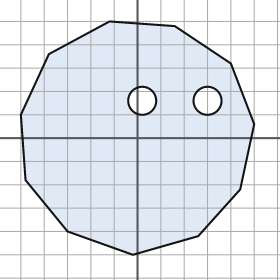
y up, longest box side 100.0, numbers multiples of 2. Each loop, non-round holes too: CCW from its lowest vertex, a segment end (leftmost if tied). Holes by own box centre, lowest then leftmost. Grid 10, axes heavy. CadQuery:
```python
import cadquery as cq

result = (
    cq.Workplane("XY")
    .moveTo(-2.0, -50.0)
    .lineTo(26.0, -42.0)
    .lineTo(44.0, -22.0)
    .lineTo(50.0, 6.0)
    .lineTo(40.0, 32.0)
    .lineTo(16.0, 48.0)
    .lineTo(-12.0, 50.0)
    .lineTo(-38.0, 36.0)
    .lineTo(-50.0, 10.0)
    .lineTo(-48.0, -18.0)
    .lineTo(-30.0, -40.0)
    .close()
    .moveTo(2.0, 16.0)
    .circle(6.0)
    .moveTo(30.0, 16.0)
    .circle(6.0)
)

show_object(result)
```